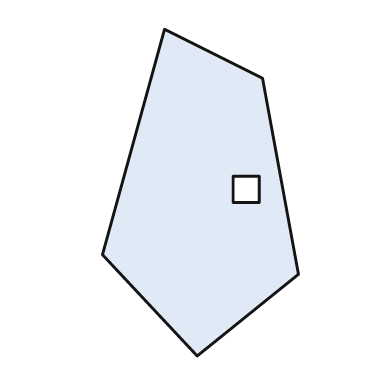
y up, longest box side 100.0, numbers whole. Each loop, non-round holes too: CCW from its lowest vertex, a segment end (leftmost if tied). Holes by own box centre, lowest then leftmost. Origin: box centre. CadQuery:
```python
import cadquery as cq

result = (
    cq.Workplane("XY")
    .moveTo(-1.0, -50.0)
    .lineTo(30.0, -25.0)
    .lineTo(19.0, 35.0)
    .lineTo(-11.0, 50.0)
    .lineTo(-30.0, -19.0)
    .close()
    .moveTo(10.0, -3.0)
    .lineTo(18.0, -3.0)
    .lineTo(18.0, 5.0)
    .lineTo(10.0, 5.0)
    .close()
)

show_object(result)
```